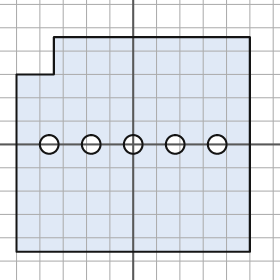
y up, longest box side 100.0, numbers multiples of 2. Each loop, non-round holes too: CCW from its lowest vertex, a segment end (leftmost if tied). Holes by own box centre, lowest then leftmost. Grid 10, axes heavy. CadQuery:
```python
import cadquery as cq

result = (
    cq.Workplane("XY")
    .moveTo(-50.0, -46.0)
    .lineTo(50.0, -46.0)
    .lineTo(50.0, 46.0)
    .lineTo(-34.0, 46.0)
    .lineTo(-34.0, 30.0)
    .lineTo(-50.0, 30.0)
    .close()
    .moveTo(-36.0, 0.0)
    .circle(4.0)
    .moveTo(-18.0, 0.0)
    .circle(4.0)
    .moveTo(0.0, 0.0)
    .circle(4.0)
    .moveTo(18.0, 0.0)
    .circle(4.0)
    .moveTo(36.0, 0.0)
    .circle(4.0)
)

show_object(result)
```